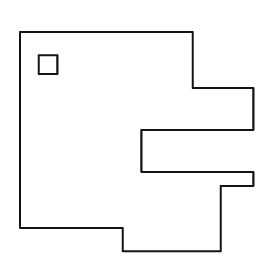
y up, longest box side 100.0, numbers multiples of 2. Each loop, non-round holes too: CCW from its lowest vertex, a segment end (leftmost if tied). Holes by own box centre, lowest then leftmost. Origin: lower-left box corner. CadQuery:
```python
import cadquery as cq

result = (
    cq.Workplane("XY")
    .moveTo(44.0, 0.0)
    .lineTo(86.0, 0.0)
    .lineTo(86.0, 28.0)
    .lineTo(100.0, 28.0)
    .lineTo(100.0, 34.0)
    .lineTo(52.0, 34.0)
    .lineTo(52.0, 52.0)
    .lineTo(100.0, 52.0)
    .lineTo(100.0, 70.0)
    .lineTo(74.0, 70.0)
    .lineTo(74.0, 94.0)
    .lineTo(0.0, 94.0)
    .lineTo(0.0, 10.0)
    .lineTo(44.0, 10.0)
    .close()
    .moveTo(8.0, 76.0)
    .lineTo(16.0, 76.0)
    .lineTo(16.0, 84.0)
    .lineTo(8.0, 84.0)
    .close()
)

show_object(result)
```